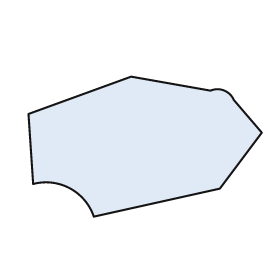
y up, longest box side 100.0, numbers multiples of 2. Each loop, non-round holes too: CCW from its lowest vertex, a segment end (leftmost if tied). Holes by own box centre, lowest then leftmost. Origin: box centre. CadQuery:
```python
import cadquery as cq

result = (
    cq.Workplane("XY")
    .moveTo(-22.0, -30.0)
    .lineTo(32.0, -18.0)
    .lineTo(50.0, 6.0)
    .lineTo(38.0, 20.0)
    .threePointArc((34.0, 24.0), (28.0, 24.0))
    .lineTo(-6.0, 30.0)
    .lineTo(-50.0, 14.0)
    .lineTo(-48.0, -16.0)
    .threePointArc((-32.0, -18.0), (-22.0, -30.0))
    .close()
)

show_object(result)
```